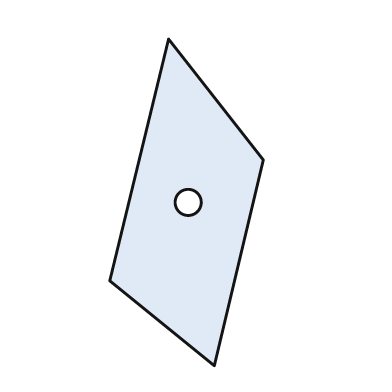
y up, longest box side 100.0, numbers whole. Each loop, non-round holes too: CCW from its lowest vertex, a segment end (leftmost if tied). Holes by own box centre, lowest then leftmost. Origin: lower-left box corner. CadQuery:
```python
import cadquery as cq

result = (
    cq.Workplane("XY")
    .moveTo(32.0, 0.0)
    .lineTo(47.0, 63.0)
    .lineTo(18.0, 100.0)
    .lineTo(0.0, 26.0)
    .close()
    .moveTo(24.0, 50.0)
    .circle(4.0)
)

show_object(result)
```